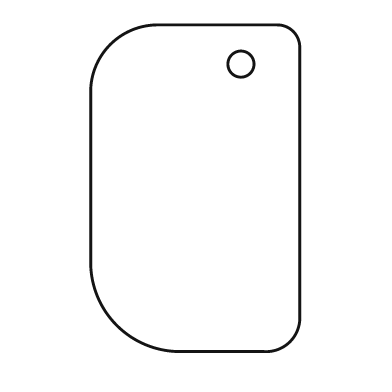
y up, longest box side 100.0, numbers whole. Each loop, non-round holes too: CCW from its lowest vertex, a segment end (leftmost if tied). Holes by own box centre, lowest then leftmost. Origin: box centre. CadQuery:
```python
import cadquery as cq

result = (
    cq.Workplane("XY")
    .moveTo(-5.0, -50.0)
    .lineTo(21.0, -50.0)
    .threePointArc((29.0, -47.0), (32.0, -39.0))
    .lineTo(32.0, 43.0)
    .threePointArc((30.0, 48.0), (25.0, 50.0))
    .lineTo(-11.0, 50.0)
    .threePointArc((-26.0, 44.0), (-32.0, 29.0))
    .lineTo(-32.0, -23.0)
    .threePointArc((-24.0, -42.0), (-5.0, -50.0))
    .close()
    .moveTo(14.0, 38.0)
    .circle(4.0)
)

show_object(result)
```